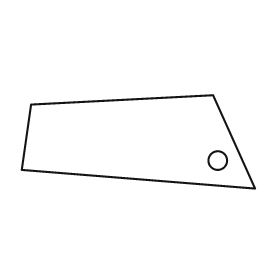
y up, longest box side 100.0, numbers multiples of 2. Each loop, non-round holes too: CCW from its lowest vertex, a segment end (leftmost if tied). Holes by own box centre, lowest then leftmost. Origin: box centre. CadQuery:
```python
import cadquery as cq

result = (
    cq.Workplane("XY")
    .moveTo(50.0, -20.0)
    .lineTo(32.0, 20.0)
    .lineTo(-46.0, 16.0)
    .lineTo(-50.0, -12.0)
    .close()
    .moveTo(34.0, -8.0)
    .circle(4.0)
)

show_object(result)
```